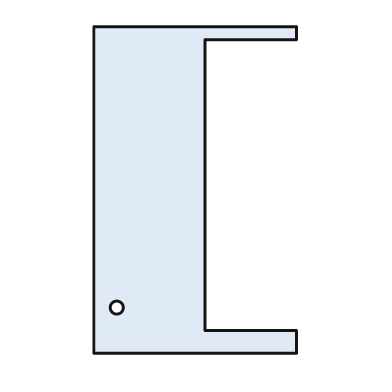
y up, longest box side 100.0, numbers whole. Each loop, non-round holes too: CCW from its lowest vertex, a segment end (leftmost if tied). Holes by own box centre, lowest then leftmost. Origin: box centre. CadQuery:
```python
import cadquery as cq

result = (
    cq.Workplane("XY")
    .moveTo(-31.0, -50.0)
    .lineTo(31.0, -50.0)
    .lineTo(31.0, -43.0)
    .lineTo(3.0, -43.0)
    .lineTo(3.0, 46.0)
    .lineTo(31.0, 46.0)
    .lineTo(31.0, 50.0)
    .lineTo(-31.0, 50.0)
    .close()
    .moveTo(-24.0, -36.0)
    .circle(2.0)
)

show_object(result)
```